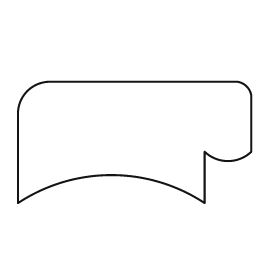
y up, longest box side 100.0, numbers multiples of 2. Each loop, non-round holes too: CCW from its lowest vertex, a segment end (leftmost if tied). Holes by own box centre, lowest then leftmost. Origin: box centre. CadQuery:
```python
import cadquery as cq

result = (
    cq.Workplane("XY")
    .moveTo(-50.0, -26.0)
    .threePointArc((-10.0, -14.0), (30.0, -26.0))
    .lineTo(30.0, -4.0)
    .threePointArc((40.0, -8.0), (50.0, -4.0))
    .lineTo(50.0, 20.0)
    .threePointArc((48.0, 24.0), (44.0, 26.0))
    .lineTo(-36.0, 26.0)
    .threePointArc((-46.0, 22.0), (-50.0, 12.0))
    .close()
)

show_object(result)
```